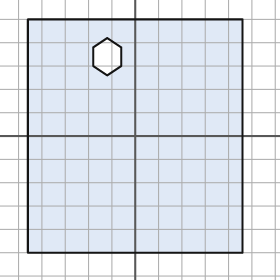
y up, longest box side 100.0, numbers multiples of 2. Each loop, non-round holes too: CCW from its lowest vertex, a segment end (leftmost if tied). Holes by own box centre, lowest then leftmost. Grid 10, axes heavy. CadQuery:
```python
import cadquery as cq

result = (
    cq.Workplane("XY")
    .moveTo(-46.0, -50.0)
    .lineTo(46.0, -50.0)
    .lineTo(46.0, 50.0)
    .lineTo(-46.0, 50.0)
    .close()
    .moveTo(-12.0, 26.0)
    .lineTo(-6.0, 30.0)
    .lineTo(-6.0, 38.0)
    .lineTo(-12.0, 42.0)
    .lineTo(-18.0, 38.0)
    .lineTo(-18.0, 30.0)
    .close()
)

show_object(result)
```